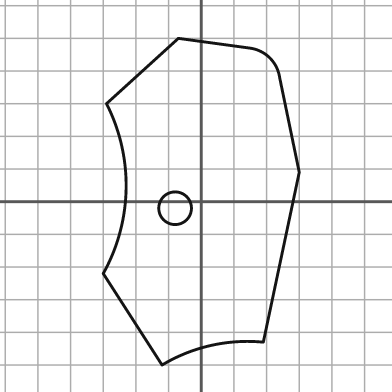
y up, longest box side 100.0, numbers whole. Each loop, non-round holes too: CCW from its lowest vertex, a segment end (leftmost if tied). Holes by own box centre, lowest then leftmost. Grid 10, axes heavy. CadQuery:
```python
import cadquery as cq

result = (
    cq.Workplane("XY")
    .moveTo(-12.0, -50.0)
    .threePointArc((3.0, -44.0), (19.0, -43.0))
    .lineTo(30.0, 9.0)
    .lineTo(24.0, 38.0)
    .threePointArc((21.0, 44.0), (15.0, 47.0))
    .lineTo(-7.0, 50.0)
    .lineTo(-29.0, 30.0)
    .threePointArc((-23.0, 4.0), (-30.0, -22.0))
    .close()
    .moveTo(-8.0, -2.0)
    .circle(5.0)
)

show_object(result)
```